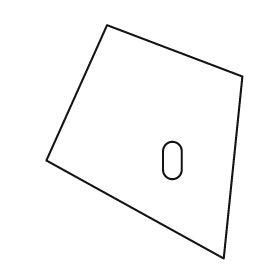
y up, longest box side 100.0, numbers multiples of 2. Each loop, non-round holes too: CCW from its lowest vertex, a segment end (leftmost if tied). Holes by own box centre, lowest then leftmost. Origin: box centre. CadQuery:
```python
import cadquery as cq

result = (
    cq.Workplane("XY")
    .moveTo(34.0, -50.0)
    .lineTo(42.0, 28.0)
    .lineTo(-16.0, 50.0)
    .lineTo(-42.0, -8.0)
    .close()
    .moveTo(8.0, -12.0)
    .threePointArc((12.0, -16.0), (16.0, -12.0))
    .lineTo(16.0, -4.0)
    .threePointArc((12.0, 0.0), (8.0, -4.0))
    .close()
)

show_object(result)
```